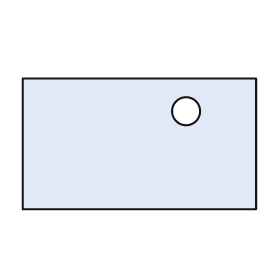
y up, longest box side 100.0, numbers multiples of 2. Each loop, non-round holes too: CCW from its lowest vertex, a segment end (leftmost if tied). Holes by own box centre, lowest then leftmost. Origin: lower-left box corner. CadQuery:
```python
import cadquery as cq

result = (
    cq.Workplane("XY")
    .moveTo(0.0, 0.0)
    .lineTo(100.0, 0.0)
    .lineTo(100.0, 56.0)
    .lineTo(0.0, 56.0)
    .close()
    .moveTo(70.0, 42.0)
    .circle(6.0)
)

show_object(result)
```